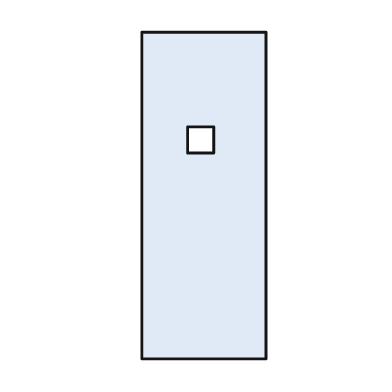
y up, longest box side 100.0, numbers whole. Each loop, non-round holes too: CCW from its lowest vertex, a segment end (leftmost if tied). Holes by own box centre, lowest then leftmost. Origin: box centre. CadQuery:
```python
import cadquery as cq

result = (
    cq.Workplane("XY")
    .moveTo(-19.0, -50.0)
    .lineTo(19.0, -50.0)
    .lineTo(19.0, 50.0)
    .lineTo(-19.0, 50.0)
    .close()
    .moveTo(-5.0, 13.0)
    .lineTo(3.0, 13.0)
    .lineTo(3.0, 21.0)
    .lineTo(-5.0, 21.0)
    .close()
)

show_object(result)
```